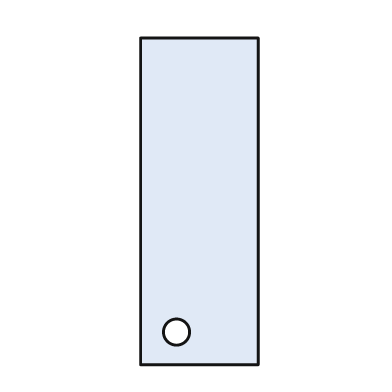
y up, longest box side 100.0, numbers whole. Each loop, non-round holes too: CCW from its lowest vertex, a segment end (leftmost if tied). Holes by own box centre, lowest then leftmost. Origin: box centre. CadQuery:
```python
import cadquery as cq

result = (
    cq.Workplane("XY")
    .moveTo(-18.0, -50.0)
    .lineTo(18.0, -50.0)
    .lineTo(18.0, 50.0)
    .lineTo(-18.0, 50.0)
    .close()
    .moveTo(-7.0, -40.0)
    .circle(4.0)
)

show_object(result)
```